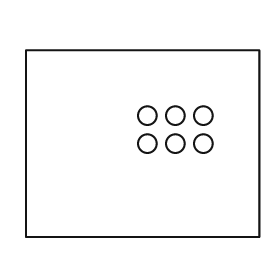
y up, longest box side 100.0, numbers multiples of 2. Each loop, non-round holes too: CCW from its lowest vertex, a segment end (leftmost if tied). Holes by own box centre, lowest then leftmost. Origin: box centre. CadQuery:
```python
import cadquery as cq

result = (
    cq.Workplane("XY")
    .moveTo(-50.0, -40.0)
    .lineTo(50.0, -40.0)
    .lineTo(50.0, 40.0)
    .lineTo(-50.0, 40.0)
    .close()
    .moveTo(2.0, 0.0)
    .circle(4.0)
    .moveTo(14.0, 0.0)
    .circle(4.0)
    .moveTo(26.0, 0.0)
    .circle(4.0)
    .moveTo(2.0, 12.0)
    .circle(4.0)
    .moveTo(14.0, 12.0)
    .circle(4.0)
    .moveTo(26.0, 12.0)
    .circle(4.0)
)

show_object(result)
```